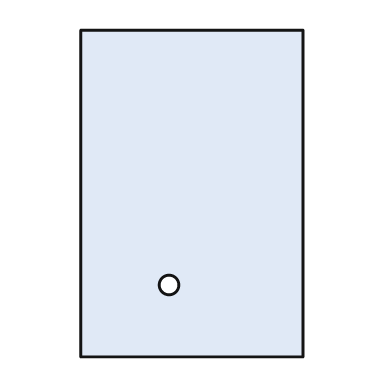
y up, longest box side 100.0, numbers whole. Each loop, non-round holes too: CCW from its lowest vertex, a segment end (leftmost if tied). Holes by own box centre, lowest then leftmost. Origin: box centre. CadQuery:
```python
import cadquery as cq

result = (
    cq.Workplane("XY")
    .moveTo(-34.0, -50.0)
    .lineTo(34.0, -50.0)
    .lineTo(34.0, 50.0)
    .lineTo(-34.0, 50.0)
    .close()
    .moveTo(-7.0, -28.0)
    .circle(3.0)
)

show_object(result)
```